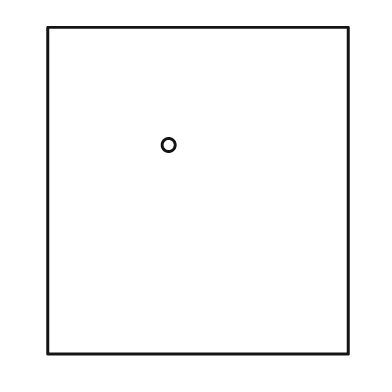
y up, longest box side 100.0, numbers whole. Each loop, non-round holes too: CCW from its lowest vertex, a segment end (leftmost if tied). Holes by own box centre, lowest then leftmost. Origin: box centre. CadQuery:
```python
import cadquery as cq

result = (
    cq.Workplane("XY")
    .moveTo(-46.0, -50.0)
    .lineTo(46.0, -50.0)
    .lineTo(46.0, 50.0)
    .lineTo(-46.0, 50.0)
    .close()
    .moveTo(-9.0, 14.0)
    .circle(2.0)
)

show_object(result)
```